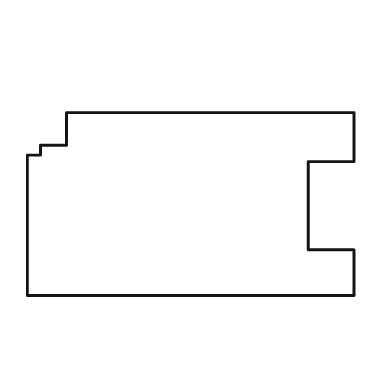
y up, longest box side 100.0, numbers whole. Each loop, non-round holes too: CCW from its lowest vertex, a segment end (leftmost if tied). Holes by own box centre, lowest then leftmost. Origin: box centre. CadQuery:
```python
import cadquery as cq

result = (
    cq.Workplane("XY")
    .moveTo(-50.0, -28.0)
    .lineTo(50.0, -28.0)
    .lineTo(50.0, -14.0)
    .lineTo(36.0, -14.0)
    .lineTo(36.0, 13.0)
    .lineTo(50.0, 13.0)
    .lineTo(50.0, 28.0)
    .lineTo(-38.0, 28.0)
    .lineTo(-38.0, 18.0)
    .lineTo(-46.0, 18.0)
    .lineTo(-46.0, 15.0)
    .lineTo(-50.0, 15.0)
    .close()
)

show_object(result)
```